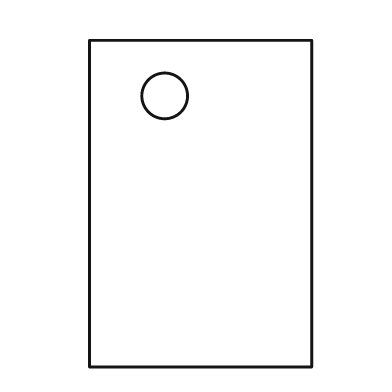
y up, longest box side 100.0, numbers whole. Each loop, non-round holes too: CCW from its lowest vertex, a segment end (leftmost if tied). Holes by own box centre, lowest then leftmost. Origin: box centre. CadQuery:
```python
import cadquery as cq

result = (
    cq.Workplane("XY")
    .moveTo(-34.0, -50.0)
    .lineTo(34.0, -50.0)
    .lineTo(34.0, 50.0)
    .lineTo(-34.0, 50.0)
    .close()
    .moveTo(-11.0, 33.0)
    .circle(7.0)
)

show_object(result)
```